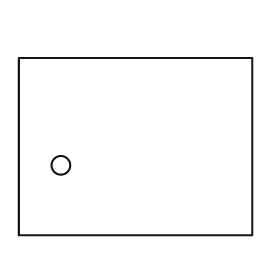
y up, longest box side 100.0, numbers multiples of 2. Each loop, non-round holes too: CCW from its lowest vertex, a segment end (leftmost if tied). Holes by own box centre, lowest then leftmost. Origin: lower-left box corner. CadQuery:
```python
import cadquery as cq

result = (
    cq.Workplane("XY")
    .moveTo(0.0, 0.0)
    .lineTo(100.0, 0.0)
    .lineTo(100.0, 76.0)
    .lineTo(0.0, 76.0)
    .close()
    .moveTo(18.0, 30.0)
    .circle(4.0)
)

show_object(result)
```